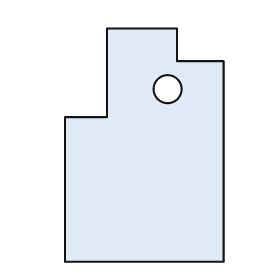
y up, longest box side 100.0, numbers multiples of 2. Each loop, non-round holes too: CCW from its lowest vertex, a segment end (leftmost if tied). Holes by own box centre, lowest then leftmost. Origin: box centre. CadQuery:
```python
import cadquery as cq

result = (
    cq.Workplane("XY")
    .moveTo(-34.0, -50.0)
    .lineTo(34.0, -50.0)
    .lineTo(34.0, 36.0)
    .lineTo(14.0, 36.0)
    .lineTo(14.0, 50.0)
    .lineTo(-16.0, 50.0)
    .lineTo(-16.0, 12.0)
    .lineTo(-34.0, 12.0)
    .close()
    .moveTo(10.0, 24.0)
    .circle(6.0)
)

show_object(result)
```